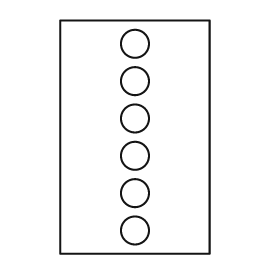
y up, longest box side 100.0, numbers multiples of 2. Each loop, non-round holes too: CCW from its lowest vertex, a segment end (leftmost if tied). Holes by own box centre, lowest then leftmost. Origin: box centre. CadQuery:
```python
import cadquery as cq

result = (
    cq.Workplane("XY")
    .moveTo(-32.0, -50.0)
    .lineTo(32.0, -50.0)
    .lineTo(32.0, 50.0)
    .lineTo(-32.0, 50.0)
    .close()
    .moveTo(0.0, -40.0)
    .circle(6.0)
    .moveTo(0.0, -24.0)
    .circle(6.0)
    .moveTo(0.0, -8.0)
    .circle(6.0)
    .moveTo(0.0, 8.0)
    .circle(6.0)
    .moveTo(0.0, 24.0)
    .circle(6.0)
    .moveTo(0.0, 40.0)
    .circle(6.0)
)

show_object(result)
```